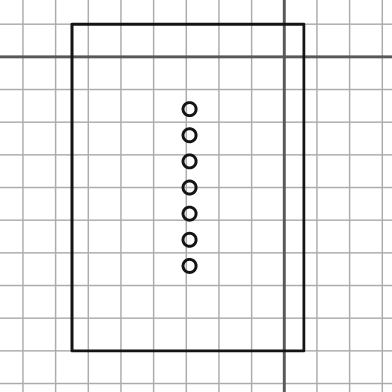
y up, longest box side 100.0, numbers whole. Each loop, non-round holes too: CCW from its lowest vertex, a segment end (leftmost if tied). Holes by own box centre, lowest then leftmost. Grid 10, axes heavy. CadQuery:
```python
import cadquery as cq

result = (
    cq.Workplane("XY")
    .moveTo(-65.0, -90.0)
    .lineTo(6.0, -90.0)
    .lineTo(6.0, 10.0)
    .lineTo(-65.0, 10.0)
    .close()
    .moveTo(-29.0, -64.0)
    .circle(2.0)
    .moveTo(-29.0, -56.0)
    .circle(2.0)
    .moveTo(-29.0, -48.0)
    .circle(2.0)
    .moveTo(-29.0, -40.0)
    .circle(2.0)
    .moveTo(-29.0, -32.0)
    .circle(2.0)
    .moveTo(-29.0, -24.0)
    .circle(2.0)
    .moveTo(-29.0, -16.0)
    .circle(2.0)
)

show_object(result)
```